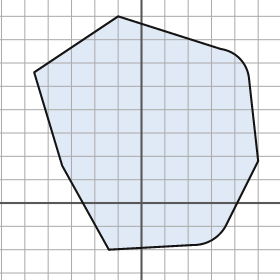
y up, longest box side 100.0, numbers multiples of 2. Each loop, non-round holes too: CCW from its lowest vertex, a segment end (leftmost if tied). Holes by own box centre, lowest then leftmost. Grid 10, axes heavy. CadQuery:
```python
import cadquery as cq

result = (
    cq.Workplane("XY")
    .moveTo(-14.0, -20.0)
    .lineTo(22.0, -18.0)
    .threePointArc((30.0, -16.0), (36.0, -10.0))
    .lineTo(50.0, 18.0)
    .lineTo(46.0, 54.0)
    .threePointArc((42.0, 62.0), (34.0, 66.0))
    .lineTo(-10.0, 80.0)
    .lineTo(-46.0, 56.0)
    .lineTo(-34.0, 16.0)
    .close()
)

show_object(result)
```